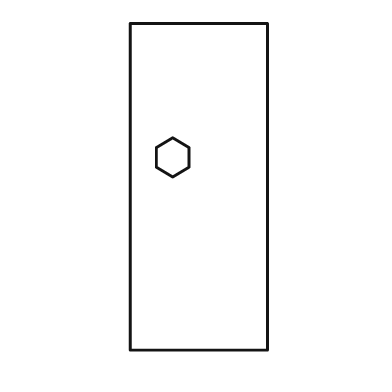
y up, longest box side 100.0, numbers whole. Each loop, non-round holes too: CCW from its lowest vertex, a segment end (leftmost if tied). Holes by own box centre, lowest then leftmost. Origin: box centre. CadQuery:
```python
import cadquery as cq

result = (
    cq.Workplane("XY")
    .moveTo(-21.0, -50.0)
    .lineTo(21.0, -50.0)
    .lineTo(21.0, 50.0)
    .lineTo(-21.0, 50.0)
    .close()
    .moveTo(-8.0, 3.0)
    .lineTo(-3.0, 6.0)
    .lineTo(-3.0, 12.0)
    .lineTo(-8.0, 15.0)
    .lineTo(-13.0, 12.0)
    .lineTo(-13.0, 6.0)
    .close()
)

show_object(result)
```